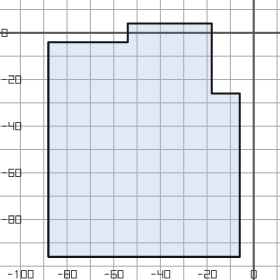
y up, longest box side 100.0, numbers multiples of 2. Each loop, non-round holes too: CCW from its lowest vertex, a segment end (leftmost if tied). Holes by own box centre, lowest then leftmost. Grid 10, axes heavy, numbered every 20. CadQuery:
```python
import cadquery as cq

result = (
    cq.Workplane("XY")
    .moveTo(-88.0, -96.0)
    .lineTo(-6.0, -96.0)
    .lineTo(-6.0, -26.0)
    .lineTo(-18.0, -26.0)
    .lineTo(-18.0, 4.0)
    .lineTo(-54.0, 4.0)
    .lineTo(-54.0, -4.0)
    .lineTo(-88.0, -4.0)
    .close()
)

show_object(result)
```